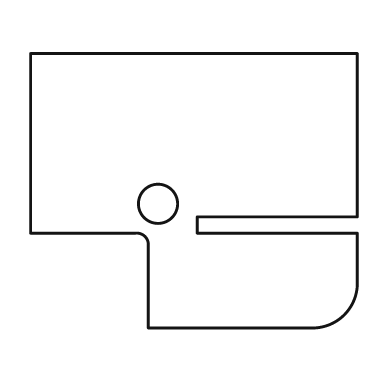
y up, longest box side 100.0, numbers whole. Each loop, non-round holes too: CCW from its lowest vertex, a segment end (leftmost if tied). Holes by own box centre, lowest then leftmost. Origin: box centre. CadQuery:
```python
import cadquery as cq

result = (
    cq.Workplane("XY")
    .moveTo(-14.0, -42.0)
    .lineTo(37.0, -42.0)
    .threePointArc((46.0, -38.0), (50.0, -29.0))
    .lineTo(50.0, -13.0)
    .lineTo(1.0, -13.0)
    .lineTo(1.0, -8.0)
    .lineTo(50.0, -8.0)
    .lineTo(50.0, 42.0)
    .lineTo(-50.0, 42.0)
    .lineTo(-50.0, -13.0)
    .lineTo(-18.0, -13.0)
    .threePointArc((-15.0, -14.0), (-14.0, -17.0))
    .close()
    .moveTo(-11.0, -4.0)
    .circle(6.0)
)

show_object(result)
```